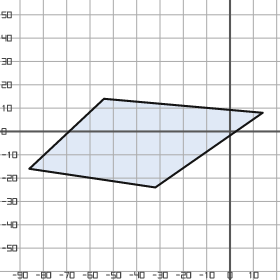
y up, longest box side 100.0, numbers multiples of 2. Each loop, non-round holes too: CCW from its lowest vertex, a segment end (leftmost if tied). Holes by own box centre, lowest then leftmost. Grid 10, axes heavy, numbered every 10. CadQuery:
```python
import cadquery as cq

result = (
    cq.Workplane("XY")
    .moveTo(-32.0, -24.0)
    .lineTo(14.0, 8.0)
    .lineTo(-54.0, 14.0)
    .lineTo(-86.0, -16.0)
    .close()
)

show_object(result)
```